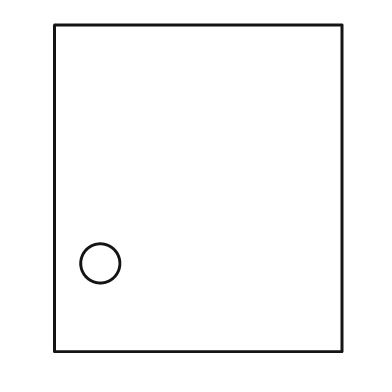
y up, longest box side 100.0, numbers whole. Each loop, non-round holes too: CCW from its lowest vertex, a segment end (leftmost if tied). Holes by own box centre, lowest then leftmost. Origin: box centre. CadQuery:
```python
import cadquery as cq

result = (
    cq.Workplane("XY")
    .moveTo(-44.0, -50.0)
    .lineTo(44.0, -50.0)
    .lineTo(44.0, 50.0)
    .lineTo(-44.0, 50.0)
    .close()
    .moveTo(-30.0, -23.0)
    .circle(6.0)
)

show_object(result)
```